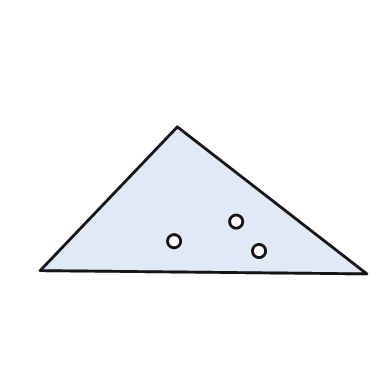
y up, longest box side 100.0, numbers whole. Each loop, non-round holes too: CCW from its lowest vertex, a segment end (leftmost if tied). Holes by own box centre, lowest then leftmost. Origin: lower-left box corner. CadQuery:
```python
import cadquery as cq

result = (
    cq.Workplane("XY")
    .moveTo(100.0, 0.0)
    .lineTo(42.0, 45.0)
    .lineTo(0.0, 1.0)
    .close()
    .moveTo(67.0, 7.0)
    .circle(2.0)
    .moveTo(41.0, 10.0)
    .circle(2.0)
    .moveTo(60.0, 16.0)
    .circle(2.0)
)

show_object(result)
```